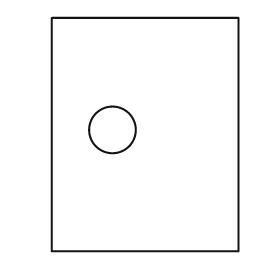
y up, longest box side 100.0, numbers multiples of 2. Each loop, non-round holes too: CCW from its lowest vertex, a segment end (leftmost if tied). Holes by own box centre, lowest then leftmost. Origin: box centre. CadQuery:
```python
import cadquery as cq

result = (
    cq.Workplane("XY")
    .moveTo(-40.0, -50.0)
    .lineTo(40.0, -50.0)
    .lineTo(40.0, 50.0)
    .lineTo(-40.0, 50.0)
    .close()
    .moveTo(-14.0, 2.0)
    .circle(10.0)
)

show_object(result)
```